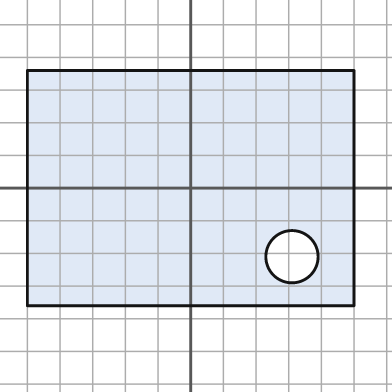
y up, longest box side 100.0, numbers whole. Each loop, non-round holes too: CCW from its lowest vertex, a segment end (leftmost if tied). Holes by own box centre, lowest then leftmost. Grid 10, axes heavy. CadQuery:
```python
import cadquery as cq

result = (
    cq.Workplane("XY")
    .moveTo(-50.0, -36.0)
    .lineTo(50.0, -36.0)
    .lineTo(50.0, 36.0)
    .lineTo(-50.0, 36.0)
    .close()
    .moveTo(31.0, -21.0)
    .circle(8.0)
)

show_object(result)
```